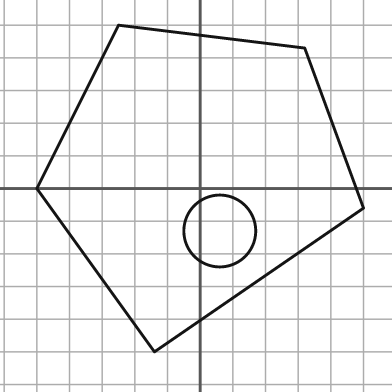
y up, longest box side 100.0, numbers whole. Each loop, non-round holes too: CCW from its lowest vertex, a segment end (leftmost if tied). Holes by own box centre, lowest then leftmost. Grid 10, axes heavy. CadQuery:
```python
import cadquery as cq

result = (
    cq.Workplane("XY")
    .moveTo(-14.0, -50.0)
    .lineTo(50.0, -6.0)
    .lineTo(32.0, 43.0)
    .lineTo(-25.0, 50.0)
    .lineTo(-50.0, 0.0)
    .close()
    .moveTo(6.0, -13.0)
    .circle(11.0)
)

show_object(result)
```